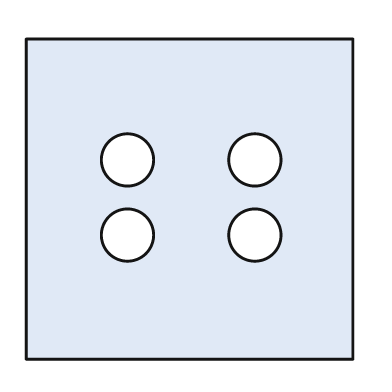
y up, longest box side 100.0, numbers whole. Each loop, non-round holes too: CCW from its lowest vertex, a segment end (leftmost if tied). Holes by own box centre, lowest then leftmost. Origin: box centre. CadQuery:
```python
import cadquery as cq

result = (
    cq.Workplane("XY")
    .moveTo(-50.0, -49.0)
    .lineTo(50.0, -49.0)
    .lineTo(50.0, 49.0)
    .lineTo(-50.0, 49.0)
    .close()
    .moveTo(-19.0, -11.0)
    .circle(8.0)
    .moveTo(20.0, -11.0)
    .circle(8.0)
    .moveTo(-19.0, 12.0)
    .circle(8.0)
    .moveTo(20.0, 12.0)
    .circle(8.0)
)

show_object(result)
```